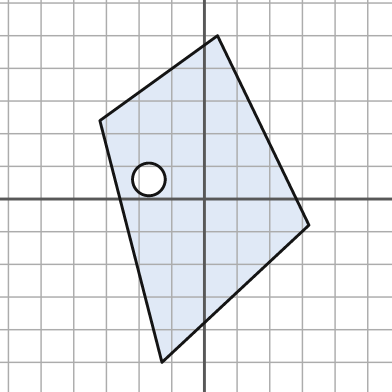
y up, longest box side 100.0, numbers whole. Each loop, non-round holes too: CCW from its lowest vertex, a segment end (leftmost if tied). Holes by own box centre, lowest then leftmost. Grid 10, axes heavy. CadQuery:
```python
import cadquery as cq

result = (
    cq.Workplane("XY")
    .moveTo(-13.0, -50.0)
    .lineTo(32.0, -8.0)
    .lineTo(4.0, 50.0)
    .lineTo(-32.0, 24.0)
    .close()
    .moveTo(-17.0, 6.0)
    .circle(5.0)
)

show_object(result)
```